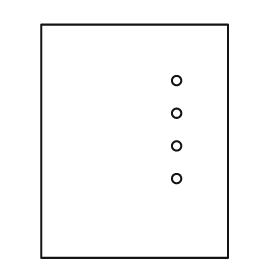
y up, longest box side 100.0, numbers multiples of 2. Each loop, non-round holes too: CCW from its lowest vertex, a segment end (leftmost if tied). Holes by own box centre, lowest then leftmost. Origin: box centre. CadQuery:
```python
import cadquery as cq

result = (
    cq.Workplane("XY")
    .moveTo(-40.0, -50.0)
    .lineTo(40.0, -50.0)
    .lineTo(40.0, 50.0)
    .lineTo(-40.0, 50.0)
    .close()
    .moveTo(18.0, -16.0)
    .circle(2.0)
    .moveTo(18.0, -2.0)
    .circle(2.0)
    .moveTo(18.0, 12.0)
    .circle(2.0)
    .moveTo(18.0, 26.0)
    .circle(2.0)
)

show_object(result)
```